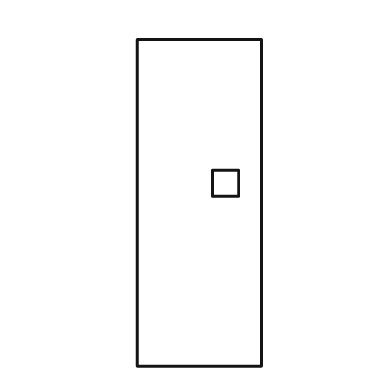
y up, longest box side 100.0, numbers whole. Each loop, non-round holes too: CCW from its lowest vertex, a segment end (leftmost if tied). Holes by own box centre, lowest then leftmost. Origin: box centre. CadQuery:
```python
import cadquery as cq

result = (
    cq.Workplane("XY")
    .moveTo(-19.0, -50.0)
    .lineTo(19.0, -50.0)
    .lineTo(19.0, 50.0)
    .lineTo(-19.0, 50.0)
    .close()
    .moveTo(4.0, 2.0)
    .lineTo(12.0, 2.0)
    .lineTo(12.0, 10.0)
    .lineTo(4.0, 10.0)
    .close()
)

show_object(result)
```